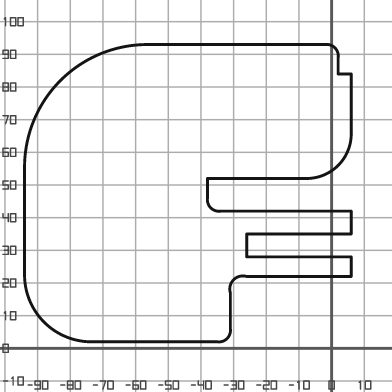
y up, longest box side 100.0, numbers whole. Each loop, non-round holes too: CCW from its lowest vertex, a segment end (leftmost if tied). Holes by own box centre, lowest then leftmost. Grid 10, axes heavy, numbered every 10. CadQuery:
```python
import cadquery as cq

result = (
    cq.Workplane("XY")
    .moveTo(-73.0, 2.0)
    .lineTo(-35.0, 2.0)
    .threePointArc((-32.0, 3.0), (-31.0, 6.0))
    .lineTo(-31.0, 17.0)
    .threePointArc((-30.0, 21.0), (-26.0, 22.0))
    .lineTo(6.0, 22.0)
    .lineTo(6.0, 28.0)
    .lineTo(-26.0, 28.0)
    .lineTo(-26.0, 35.0)
    .lineTo(6.0, 35.0)
    .lineTo(6.0, 42.0)
    .lineTo(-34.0, 42.0)
    .threePointArc((-37.0, 43.0), (-38.0, 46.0))
    .lineTo(-38.0, 52.0)
    .lineTo(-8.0, 52.0)
    .threePointArc((2.0, 56.0), (6.0, 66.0))
    .lineTo(6.0, 84.0)
    .lineTo(2.0, 84.0)
    .lineTo(2.0, 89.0)
    .threePointArc((1.0, 92.0), (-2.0, 93.0))
    .lineTo(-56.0, 93.0)
    .threePointArc((-83.0, 82.0), (-94.0, 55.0))
    .lineTo(-94.0, 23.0)
    .threePointArc((-88.0, 8.0), (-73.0, 2.0))
    .close()
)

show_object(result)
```